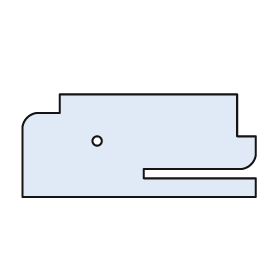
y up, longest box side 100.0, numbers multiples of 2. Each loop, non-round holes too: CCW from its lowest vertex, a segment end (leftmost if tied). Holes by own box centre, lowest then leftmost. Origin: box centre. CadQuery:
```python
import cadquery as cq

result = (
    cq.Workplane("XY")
    .moveTo(-50.0, -22.0)
    .lineTo(50.0, -22.0)
    .lineTo(50.0, -14.0)
    .lineTo(2.0, -14.0)
    .lineTo(2.0, -10.0)
    .lineTo(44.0, -10.0)
    .threePointArc((48.0, -8.0), (50.0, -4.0))
    .lineTo(50.0, 4.0)
    .lineTo(42.0, 4.0)
    .lineTo(42.0, 22.0)
    .lineTo(-34.0, 22.0)
    .lineTo(-34.0, 14.0)
    .lineTo(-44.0, 14.0)
    .threePointArc((-48.0, 12.0), (-50.0, 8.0))
    .close()
    .moveTo(-18.0, 2.0)
    .circle(2.0)
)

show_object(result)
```